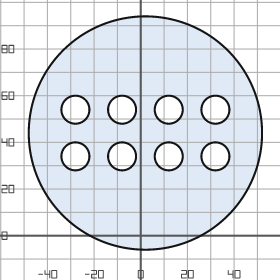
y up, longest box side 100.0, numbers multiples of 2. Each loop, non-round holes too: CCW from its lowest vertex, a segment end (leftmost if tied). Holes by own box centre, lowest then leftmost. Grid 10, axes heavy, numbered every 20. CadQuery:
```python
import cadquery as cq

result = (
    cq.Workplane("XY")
    .moveTo(2.0, 44.0)
    .circle(50.0)
    .moveTo(-28.0, 34.0)
    .circle(6.0)
    .moveTo(-8.0, 34.0)
    .circle(6.0)
    .moveTo(12.0, 34.0)
    .circle(6.0)
    .moveTo(32.0, 34.0)
    .circle(6.0)
    .moveTo(-28.0, 54.0)
    .circle(6.0)
    .moveTo(-8.0, 54.0)
    .circle(6.0)
    .moveTo(12.0, 54.0)
    .circle(6.0)
    .moveTo(32.0, 54.0)
    .circle(6.0)
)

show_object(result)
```